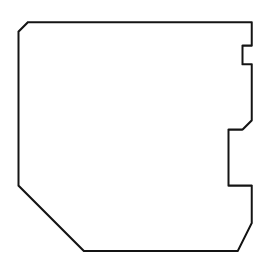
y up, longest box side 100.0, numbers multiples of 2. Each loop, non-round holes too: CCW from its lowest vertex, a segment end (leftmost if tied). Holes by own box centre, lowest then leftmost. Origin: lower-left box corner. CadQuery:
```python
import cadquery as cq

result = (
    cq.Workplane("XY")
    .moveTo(28.0, 0.0)
    .lineTo(94.0, 0.0)
    .lineTo(100.0, 12.0)
    .lineTo(100.0, 28.0)
    .lineTo(90.0, 28.0)
    .lineTo(90.0, 52.0)
    .lineTo(96.0, 52.0)
    .lineTo(100.0, 56.0)
    .lineTo(100.0, 80.0)
    .lineTo(96.0, 80.0)
    .lineTo(96.0, 88.0)
    .lineTo(100.0, 88.0)
    .lineTo(100.0, 98.0)
    .lineTo(4.0, 98.0)
    .lineTo(0.0, 94.0)
    .lineTo(0.0, 28.0)
    .close()
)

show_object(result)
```